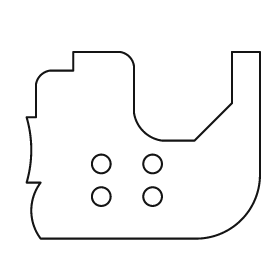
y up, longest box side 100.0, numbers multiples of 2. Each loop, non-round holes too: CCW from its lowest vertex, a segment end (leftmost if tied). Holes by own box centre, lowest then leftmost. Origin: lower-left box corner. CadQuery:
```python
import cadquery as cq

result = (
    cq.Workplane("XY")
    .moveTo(6.0, 0.0)
    .lineTo(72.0, 0.0)
    .threePointArc((92.0, 8.0), (100.0, 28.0))
    .lineTo(100.0, 80.0)
    .lineTo(88.0, 80.0)
    .lineTo(88.0, 58.0)
    .lineTo(72.0, 42.0)
    .lineTo(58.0, 42.0)
    .threePointArc((50.0, 46.0), (46.0, 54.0))
    .lineTo(46.0, 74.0)
    .threePointArc((44.0, 78.0), (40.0, 80.0))
    .lineTo(20.0, 80.0)
    .lineTo(20.0, 72.0)
    .lineTo(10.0, 72.0)
    .threePointArc((6.0, 70.0), (4.0, 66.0))
    .lineTo(4.0, 52.0)
    .lineTo(0.0, 52.0)
    .threePointArc((2.0, 38.0), (0.0, 24.0))
    .lineTo(6.0, 24.0)
    .threePointArc((2.0, 12.0), (6.0, 0.0))
    .close()
    .moveTo(32.0, 18.0)
    .circle(4.0)
    .moveTo(54.0, 18.0)
    .circle(4.0)
    .moveTo(32.0, 32.0)
    .circle(4.0)
    .moveTo(54.0, 32.0)
    .circle(4.0)
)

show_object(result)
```